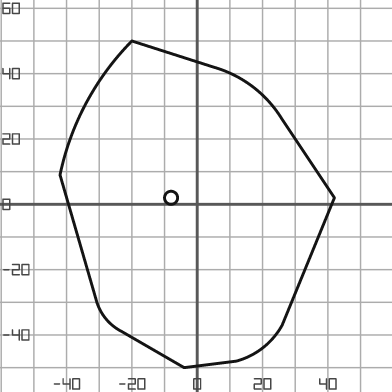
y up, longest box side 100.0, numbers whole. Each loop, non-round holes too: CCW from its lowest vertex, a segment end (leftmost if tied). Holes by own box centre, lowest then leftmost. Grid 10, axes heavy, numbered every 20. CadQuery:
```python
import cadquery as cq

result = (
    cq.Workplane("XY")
    .moveTo(-4.0, -50.0)
    .lineTo(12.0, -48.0)
    .threePointArc((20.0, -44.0), (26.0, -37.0))
    .lineTo(42.0, 2.0)
    .lineTo(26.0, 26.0)
    .threePointArc((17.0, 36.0), (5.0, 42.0))
    .lineTo(-20.0, 50.0)
    .threePointArc((-34.0, 31.0), (-42.0, 9.0))
    .lineTo(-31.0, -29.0)
    .threePointArc((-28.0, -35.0), (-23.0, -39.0))
    .close()
    .moveTo(-8.0, 2.0)
    .circle(2.0)
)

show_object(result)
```